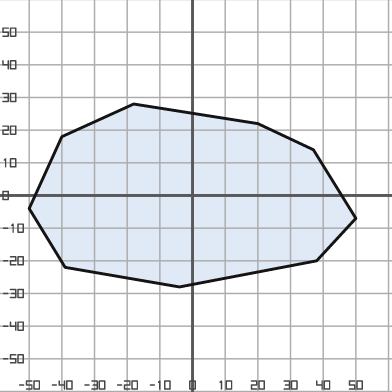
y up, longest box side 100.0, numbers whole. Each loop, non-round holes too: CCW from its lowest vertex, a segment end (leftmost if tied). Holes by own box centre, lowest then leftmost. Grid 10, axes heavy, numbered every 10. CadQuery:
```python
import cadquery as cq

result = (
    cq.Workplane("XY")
    .moveTo(-4.0, -28.0)
    .lineTo(38.0, -20.0)
    .lineTo(50.0, -7.0)
    .lineTo(37.0, 14.0)
    .lineTo(20.0, 22.0)
    .lineTo(-18.0, 28.0)
    .lineTo(-40.0, 18.0)
    .lineTo(-50.0, -4.0)
    .lineTo(-39.0, -22.0)
    .close()
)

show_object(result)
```